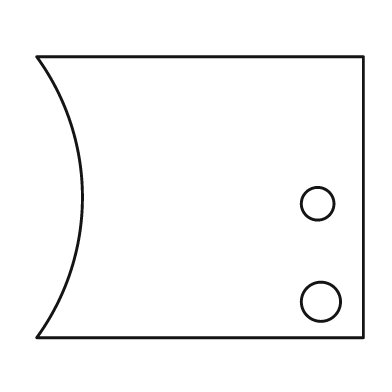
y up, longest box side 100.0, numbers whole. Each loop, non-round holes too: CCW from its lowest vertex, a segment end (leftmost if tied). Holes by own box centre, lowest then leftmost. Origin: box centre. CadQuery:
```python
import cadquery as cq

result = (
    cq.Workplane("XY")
    .moveTo(-50.0, -43.0)
    .lineTo(50.0, -43.0)
    .lineTo(50.0, 43.0)
    .lineTo(-50.0, 43.0)
    .threePointArc((-36.0, 0.0), (-50.0, -43.0))
    .close()
    .moveTo(37.0, -32.0)
    .circle(6.0)
    .moveTo(36.0, -2.0)
    .circle(5.0)
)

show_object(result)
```